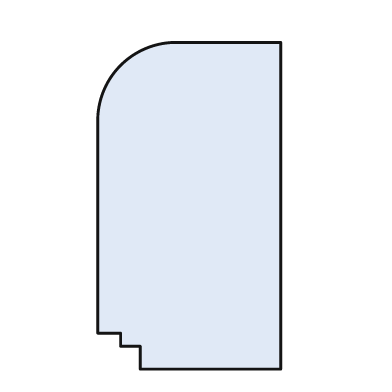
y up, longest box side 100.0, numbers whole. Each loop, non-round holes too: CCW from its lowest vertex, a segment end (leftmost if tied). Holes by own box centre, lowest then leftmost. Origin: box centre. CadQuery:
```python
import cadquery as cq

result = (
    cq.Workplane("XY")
    .moveTo(-15.0, -50.0)
    .lineTo(28.0, -50.0)
    .lineTo(28.0, 50.0)
    .lineTo(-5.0, 50.0)
    .threePointArc((-21.0, 43.0), (-28.0, 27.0))
    .lineTo(-28.0, -39.0)
    .lineTo(-21.0, -39.0)
    .lineTo(-21.0, -43.0)
    .lineTo(-15.0, -43.0)
    .close()
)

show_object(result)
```